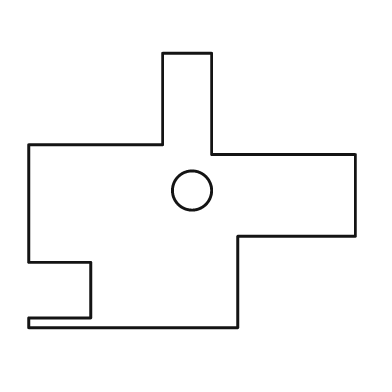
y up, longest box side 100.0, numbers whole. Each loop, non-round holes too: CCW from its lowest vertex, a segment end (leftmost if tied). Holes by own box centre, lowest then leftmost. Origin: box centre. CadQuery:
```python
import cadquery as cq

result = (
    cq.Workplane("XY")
    .moveTo(-50.0, -42.0)
    .lineTo(14.0, -42.0)
    .lineTo(14.0, -14.0)
    .lineTo(50.0, -14.0)
    .lineTo(50.0, 11.0)
    .lineTo(6.0, 11.0)
    .lineTo(6.0, 42.0)
    .lineTo(-9.0, 42.0)
    .lineTo(-9.0, 14.0)
    .lineTo(-50.0, 14.0)
    .lineTo(-50.0, -22.0)
    .lineTo(-31.0, -22.0)
    .lineTo(-31.0, -39.0)
    .lineTo(-50.0, -39.0)
    .close()
    .moveTo(0.0, 0.0)
    .circle(6.0)
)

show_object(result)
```